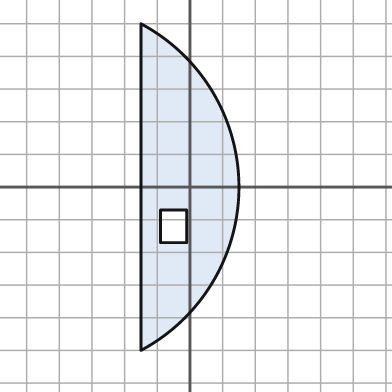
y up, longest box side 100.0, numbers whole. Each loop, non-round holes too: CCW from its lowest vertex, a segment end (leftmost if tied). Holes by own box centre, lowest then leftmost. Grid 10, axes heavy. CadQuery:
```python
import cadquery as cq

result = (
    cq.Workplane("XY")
    .moveTo(-15.0, -50.0)
    .threePointArc((15.0, 0.0), (-15.0, 50.0))
    .close()
    .moveTo(-9.0, -17.0)
    .lineTo(-1.0, -17.0)
    .lineTo(-1.0, -7.0)
    .lineTo(-9.0, -7.0)
    .close()
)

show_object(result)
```